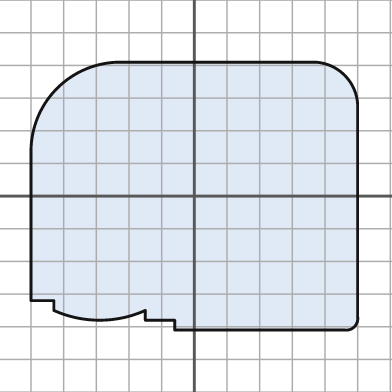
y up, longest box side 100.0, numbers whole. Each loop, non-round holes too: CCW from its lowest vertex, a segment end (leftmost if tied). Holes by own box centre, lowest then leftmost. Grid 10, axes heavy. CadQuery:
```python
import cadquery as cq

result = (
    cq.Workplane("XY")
    .moveTo(-6.0, -41.0)
    .lineTo(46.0, -41.0)
    .threePointArc((49.0, -40.0), (50.0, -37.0))
    .lineTo(50.0, 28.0)
    .threePointArc((46.0, 37.0), (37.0, 41.0))
    .lineTo(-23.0, 41.0)
    .threePointArc((-42.0, 33.0), (-50.0, 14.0))
    .lineTo(-50.0, -32.0)
    .lineTo(-43.0, -32.0)
    .lineTo(-43.0, -35.0)
    .threePointArc((-29.0, -38.0), (-15.0, -35.0))
    .lineTo(-15.0, -38.0)
    .lineTo(-6.0, -38.0)
    .close()
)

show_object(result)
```